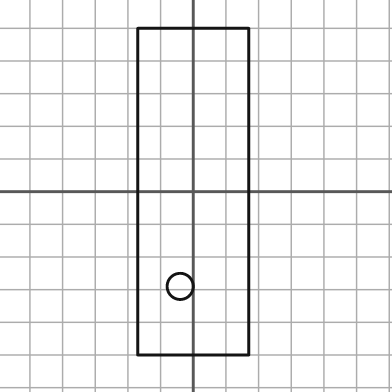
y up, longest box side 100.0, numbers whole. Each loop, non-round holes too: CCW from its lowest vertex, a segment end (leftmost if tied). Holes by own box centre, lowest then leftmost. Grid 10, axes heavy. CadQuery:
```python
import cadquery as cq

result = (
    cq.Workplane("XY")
    .moveTo(-17.0, -50.0)
    .lineTo(17.0, -50.0)
    .lineTo(17.0, 50.0)
    .lineTo(-17.0, 50.0)
    .close()
    .moveTo(-4.0, -29.0)
    .circle(4.0)
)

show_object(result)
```